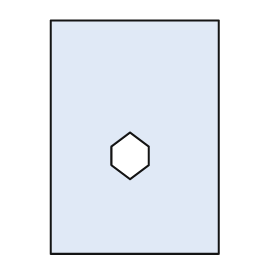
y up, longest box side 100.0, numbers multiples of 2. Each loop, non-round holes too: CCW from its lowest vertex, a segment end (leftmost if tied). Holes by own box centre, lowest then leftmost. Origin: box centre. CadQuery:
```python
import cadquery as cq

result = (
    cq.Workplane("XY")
    .moveTo(-36.0, -50.0)
    .lineTo(36.0, -50.0)
    .lineTo(36.0, 50.0)
    .lineTo(-36.0, 50.0)
    .close()
    .moveTo(-2.0, -18.0)
    .lineTo(6.0, -12.0)
    .lineTo(6.0, -4.0)
    .lineTo(-2.0, 2.0)
    .lineTo(-10.0, -4.0)
    .lineTo(-10.0, -12.0)
    .close()
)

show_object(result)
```